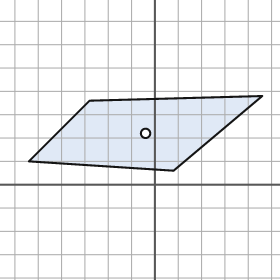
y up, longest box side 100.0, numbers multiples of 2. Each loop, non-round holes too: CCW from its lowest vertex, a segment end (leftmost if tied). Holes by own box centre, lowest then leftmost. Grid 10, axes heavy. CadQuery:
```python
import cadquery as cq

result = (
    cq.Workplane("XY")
    .moveTo(8.0, 6.0)
    .lineTo(46.0, 38.0)
    .lineTo(-28.0, 36.0)
    .lineTo(-54.0, 10.0)
    .close()
    .moveTo(-4.0, 22.0)
    .circle(2.0)
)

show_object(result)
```